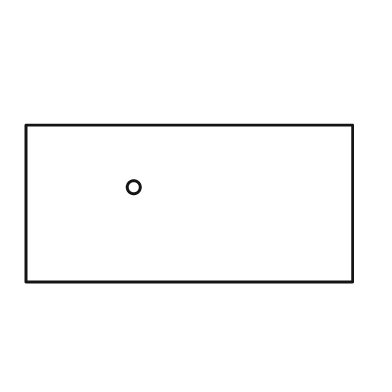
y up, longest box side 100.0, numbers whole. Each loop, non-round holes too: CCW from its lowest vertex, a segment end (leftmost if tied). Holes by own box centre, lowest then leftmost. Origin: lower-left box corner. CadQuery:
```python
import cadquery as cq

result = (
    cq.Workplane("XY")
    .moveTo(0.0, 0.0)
    .lineTo(100.0, 0.0)
    .lineTo(100.0, 48.0)
    .lineTo(0.0, 48.0)
    .close()
    .moveTo(33.0, 29.0)
    .circle(2.0)
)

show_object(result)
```